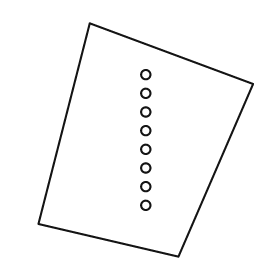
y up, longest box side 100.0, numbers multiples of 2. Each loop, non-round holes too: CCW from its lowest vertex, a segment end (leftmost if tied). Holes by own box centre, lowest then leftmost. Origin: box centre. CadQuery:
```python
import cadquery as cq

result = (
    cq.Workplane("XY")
    .moveTo(14.0, -50.0)
    .lineTo(46.0, 24.0)
    .lineTo(-24.0, 50.0)
    .lineTo(-46.0, -36.0)
    .close()
    .moveTo(0.0, -28.0)
    .circle(2.0)
    .moveTo(0.0, -20.0)
    .circle(2.0)
    .moveTo(0.0, -12.0)
    .circle(2.0)
    .moveTo(0.0, -4.0)
    .circle(2.0)
    .moveTo(0.0, 4.0)
    .circle(2.0)
    .moveTo(0.0, 12.0)
    .circle(2.0)
    .moveTo(0.0, 20.0)
    .circle(2.0)
    .moveTo(0.0, 28.0)
    .circle(2.0)
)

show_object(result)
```